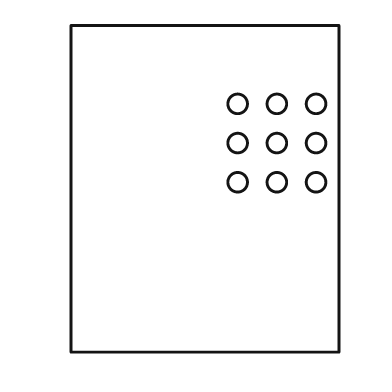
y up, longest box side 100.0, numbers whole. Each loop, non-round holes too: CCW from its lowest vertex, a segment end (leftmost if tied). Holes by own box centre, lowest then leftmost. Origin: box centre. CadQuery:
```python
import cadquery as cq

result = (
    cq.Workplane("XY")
    .moveTo(-41.0, -50.0)
    .lineTo(41.0, -50.0)
    .lineTo(41.0, 50.0)
    .lineTo(-41.0, 50.0)
    .close()
    .moveTo(10.0, 2.0)
    .circle(3.0)
    .moveTo(22.0, 2.0)
    .circle(3.0)
    .moveTo(34.0, 2.0)
    .circle(3.0)
    .moveTo(10.0, 14.0)
    .circle(3.0)
    .moveTo(22.0, 14.0)
    .circle(3.0)
    .moveTo(34.0, 14.0)
    .circle(3.0)
    .moveTo(10.0, 26.0)
    .circle(3.0)
    .moveTo(22.0, 26.0)
    .circle(3.0)
    .moveTo(34.0, 26.0)
    .circle(3.0)
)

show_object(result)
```